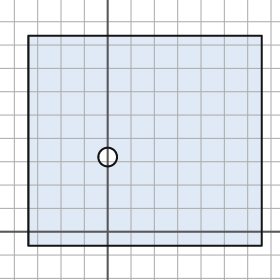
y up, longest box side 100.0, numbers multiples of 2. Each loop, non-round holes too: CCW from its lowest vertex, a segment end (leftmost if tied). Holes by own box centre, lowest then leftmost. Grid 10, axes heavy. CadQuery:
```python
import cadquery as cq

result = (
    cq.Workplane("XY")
    .moveTo(-34.0, -6.0)
    .lineTo(66.0, -6.0)
    .lineTo(66.0, 84.0)
    .lineTo(-34.0, 84.0)
    .close()
    .moveTo(0.0, 32.0)
    .circle(4.0)
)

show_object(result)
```